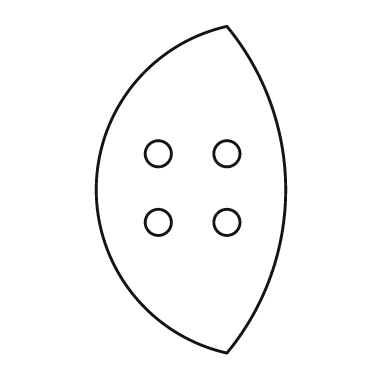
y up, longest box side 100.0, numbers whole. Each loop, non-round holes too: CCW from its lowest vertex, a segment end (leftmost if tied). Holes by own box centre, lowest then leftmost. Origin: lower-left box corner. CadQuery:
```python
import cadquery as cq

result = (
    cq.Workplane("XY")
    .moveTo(40.0, 0.0)
    .threePointArc((58.0, 50.0), (40.0, 100.0))
    .threePointArc((0.0, 50.0), (40.0, 0.0))
    .close()
    .moveTo(19.0, 40.0)
    .circle(4.0)
    .moveTo(40.0, 40.0)
    .circle(4.0)
    .moveTo(19.0, 61.0)
    .circle(4.0)
    .moveTo(40.0, 61.0)
    .circle(4.0)
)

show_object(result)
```